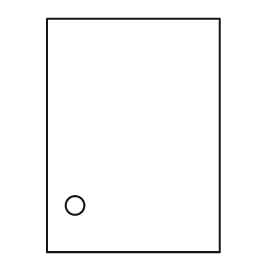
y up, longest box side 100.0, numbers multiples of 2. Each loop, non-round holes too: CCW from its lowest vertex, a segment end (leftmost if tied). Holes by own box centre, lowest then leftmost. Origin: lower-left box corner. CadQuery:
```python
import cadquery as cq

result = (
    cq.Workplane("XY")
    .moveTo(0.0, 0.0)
    .lineTo(74.0, 0.0)
    .lineTo(74.0, 100.0)
    .lineTo(0.0, 100.0)
    .close()
    .moveTo(12.0, 20.0)
    .circle(4.0)
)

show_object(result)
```